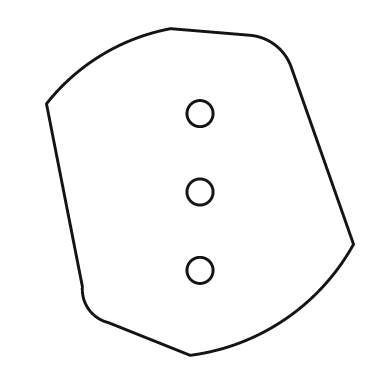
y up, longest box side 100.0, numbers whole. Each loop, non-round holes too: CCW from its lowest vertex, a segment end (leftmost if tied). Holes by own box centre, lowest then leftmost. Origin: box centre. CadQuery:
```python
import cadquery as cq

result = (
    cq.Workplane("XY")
    .moveTo(-3.0, -50.0)
    .threePointArc((26.0, -39.0), (47.0, -16.0))
    .lineTo(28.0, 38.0)
    .threePointArc((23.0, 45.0), (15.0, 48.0))
    .lineTo(-9.0, 50.0)
    .threePointArc((-30.0, 42.0), (-47.0, 27.0))
    .lineTo(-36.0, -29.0)
    .threePointArc((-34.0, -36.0), (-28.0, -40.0))
    .close()
    .moveTo(0.0, -24.0)
    .circle(4.0)
    .moveTo(0.0, 0.0)
    .circle(4.0)
    .moveTo(0.0, 24.0)
    .circle(4.0)
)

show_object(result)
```